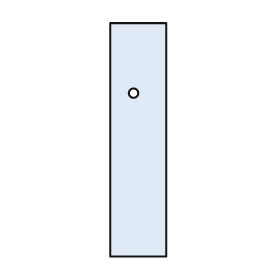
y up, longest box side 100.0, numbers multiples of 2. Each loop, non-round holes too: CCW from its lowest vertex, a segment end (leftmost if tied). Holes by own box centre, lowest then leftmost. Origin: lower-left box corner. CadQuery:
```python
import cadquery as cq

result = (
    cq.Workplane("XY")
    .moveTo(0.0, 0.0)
    .lineTo(24.0, 0.0)
    .lineTo(24.0, 100.0)
    .lineTo(0.0, 100.0)
    .close()
    .moveTo(10.0, 70.0)
    .circle(2.0)
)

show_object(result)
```